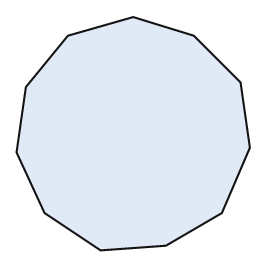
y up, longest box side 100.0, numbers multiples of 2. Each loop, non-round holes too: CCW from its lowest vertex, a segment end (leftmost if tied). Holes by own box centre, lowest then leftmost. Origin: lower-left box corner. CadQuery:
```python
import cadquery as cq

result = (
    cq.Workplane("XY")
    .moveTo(36.0, 0.0)
    .lineTo(64.0, 2.0)
    .lineTo(88.0, 16.0)
    .lineTo(100.0, 44.0)
    .lineTo(96.0, 72.0)
    .lineTo(76.0, 92.0)
    .lineTo(50.0, 100.0)
    .lineTo(22.0, 92.0)
    .lineTo(4.0, 70.0)
    .lineTo(0.0, 42.0)
    .lineTo(12.0, 16.0)
    .close()
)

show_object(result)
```